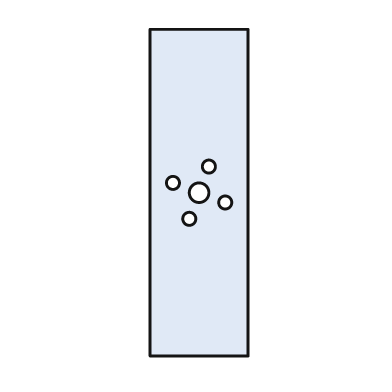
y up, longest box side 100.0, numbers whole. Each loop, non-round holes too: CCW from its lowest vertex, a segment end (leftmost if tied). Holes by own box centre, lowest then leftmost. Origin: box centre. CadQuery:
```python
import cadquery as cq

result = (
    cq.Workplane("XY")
    .moveTo(-15.0, -50.0)
    .lineTo(15.0, -50.0)
    .lineTo(15.0, 50.0)
    .lineTo(-15.0, 50.0)
    .close()
    .moveTo(-3.0, -8.0)
    .circle(2.0)
    .moveTo(8.0, -3.0)
    .circle(2.0)
    .moveTo(0.0, 0.0)
    .circle(3.0)
    .moveTo(-8.0, 3.0)
    .circle(2.0)
    .moveTo(3.0, 8.0)
    .circle(2.0)
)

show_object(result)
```